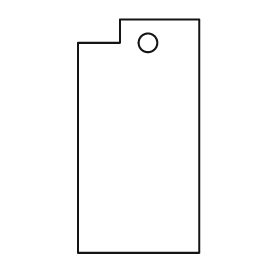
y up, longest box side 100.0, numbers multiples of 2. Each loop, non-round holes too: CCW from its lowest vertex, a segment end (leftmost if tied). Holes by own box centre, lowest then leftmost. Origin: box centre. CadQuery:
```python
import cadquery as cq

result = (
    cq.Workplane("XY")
    .moveTo(-26.0, -50.0)
    .lineTo(26.0, -50.0)
    .lineTo(26.0, 50.0)
    .lineTo(-8.0, 50.0)
    .lineTo(-8.0, 40.0)
    .lineTo(-26.0, 40.0)
    .close()
    .moveTo(4.0, 40.0)
    .circle(4.0)
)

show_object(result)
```